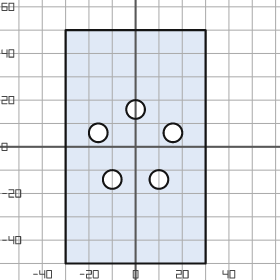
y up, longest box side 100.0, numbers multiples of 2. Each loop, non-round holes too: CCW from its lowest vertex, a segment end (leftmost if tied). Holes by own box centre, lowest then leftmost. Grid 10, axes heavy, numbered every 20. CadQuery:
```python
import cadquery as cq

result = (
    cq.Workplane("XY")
    .moveTo(-30.0, -50.0)
    .lineTo(30.0, -50.0)
    .lineTo(30.0, 50.0)
    .lineTo(-30.0, 50.0)
    .close()
    .moveTo(-10.0, -14.0)
    .circle(4.0)
    .moveTo(10.0, -14.0)
    .circle(4.0)
    .moveTo(-16.0, 6.0)
    .circle(4.0)
    .moveTo(16.0, 6.0)
    .circle(4.0)
    .moveTo(0.0, 16.0)
    .circle(4.0)
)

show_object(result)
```